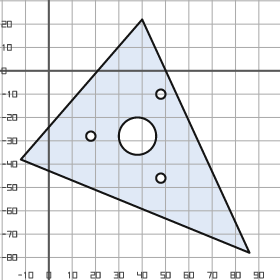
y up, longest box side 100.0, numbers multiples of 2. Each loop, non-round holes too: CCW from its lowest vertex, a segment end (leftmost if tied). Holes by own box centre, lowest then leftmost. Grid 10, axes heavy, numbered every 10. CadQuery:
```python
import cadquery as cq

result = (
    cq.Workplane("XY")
    .moveTo(86.0, -78.0)
    .lineTo(40.0, 22.0)
    .lineTo(-12.0, -38.0)
    .close()
    .moveTo(48.0, -46.0)
    .circle(2.0)
    .moveTo(18.0, -28.0)
    .circle(2.0)
    .moveTo(38.0, -28.0)
    .circle(8.0)
    .moveTo(48.0, -10.0)
    .circle(2.0)
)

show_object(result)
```